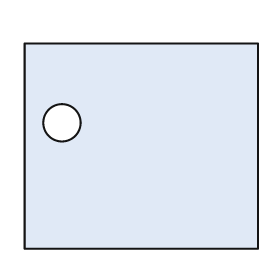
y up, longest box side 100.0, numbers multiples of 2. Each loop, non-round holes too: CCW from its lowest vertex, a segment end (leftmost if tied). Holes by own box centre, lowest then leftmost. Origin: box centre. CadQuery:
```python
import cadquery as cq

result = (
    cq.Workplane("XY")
    .moveTo(-50.0, -44.0)
    .lineTo(50.0, -44.0)
    .lineTo(50.0, 44.0)
    .lineTo(-50.0, 44.0)
    .close()
    .moveTo(-34.0, 10.0)
    .circle(8.0)
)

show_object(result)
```